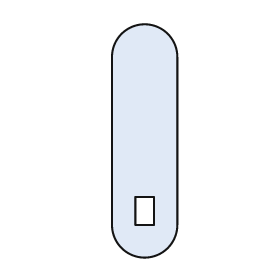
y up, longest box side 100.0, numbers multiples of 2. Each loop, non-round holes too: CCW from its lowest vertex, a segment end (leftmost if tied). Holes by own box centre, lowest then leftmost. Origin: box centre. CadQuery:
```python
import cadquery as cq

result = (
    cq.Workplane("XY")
    .moveTo(-14.0, -36.0)
    .threePointArc((0.0, -50.0), (14.0, -36.0))
    .lineTo(14.0, 36.0)
    .threePointArc((0.0, 50.0), (-14.0, 36.0))
    .close()
    .moveTo(-4.0, -36.0)
    .lineTo(4.0, -36.0)
    .lineTo(4.0, -24.0)
    .lineTo(-4.0, -24.0)
    .close()
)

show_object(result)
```